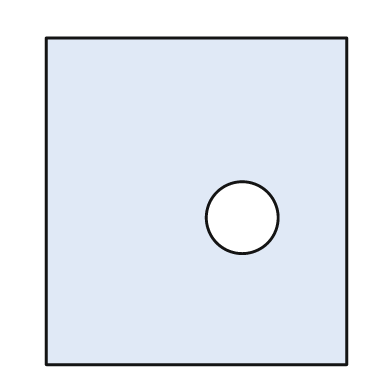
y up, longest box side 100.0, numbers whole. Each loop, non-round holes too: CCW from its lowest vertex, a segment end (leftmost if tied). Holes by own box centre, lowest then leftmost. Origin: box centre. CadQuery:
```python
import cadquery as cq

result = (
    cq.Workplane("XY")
    .moveTo(-46.0, -50.0)
    .lineTo(46.0, -50.0)
    .lineTo(46.0, 50.0)
    .lineTo(-46.0, 50.0)
    .close()
    .moveTo(14.0, -5.0)
    .circle(11.0)
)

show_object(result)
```